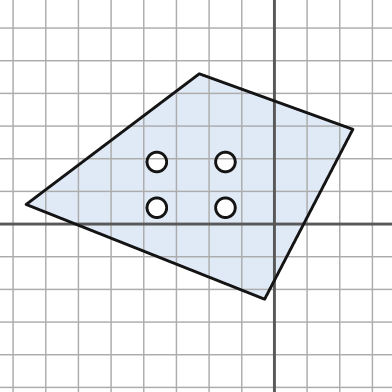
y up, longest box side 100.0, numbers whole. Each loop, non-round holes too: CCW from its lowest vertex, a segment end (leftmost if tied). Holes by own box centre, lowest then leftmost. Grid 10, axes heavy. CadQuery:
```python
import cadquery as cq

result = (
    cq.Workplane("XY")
    .moveTo(-3.0, -23.0)
    .lineTo(24.0, 29.0)
    .lineTo(-23.0, 46.0)
    .lineTo(-76.0, 6.0)
    .close()
    .moveTo(-36.0, 5.0)
    .circle(3.0)
    .moveTo(-15.0, 5.0)
    .circle(3.0)
    .moveTo(-36.0, 19.0)
    .circle(3.0)
    .moveTo(-15.0, 19.0)
    .circle(3.0)
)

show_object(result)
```